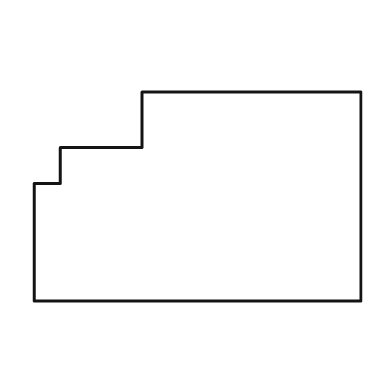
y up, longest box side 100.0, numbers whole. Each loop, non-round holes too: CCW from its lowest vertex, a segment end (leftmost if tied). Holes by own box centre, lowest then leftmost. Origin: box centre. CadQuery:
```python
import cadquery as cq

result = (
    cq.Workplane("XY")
    .moveTo(-50.0, -32.0)
    .lineTo(50.0, -32.0)
    .lineTo(50.0, 32.0)
    .lineTo(-17.0, 32.0)
    .lineTo(-17.0, 15.0)
    .lineTo(-42.0, 15.0)
    .lineTo(-42.0, 4.0)
    .lineTo(-50.0, 4.0)
    .close()
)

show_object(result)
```